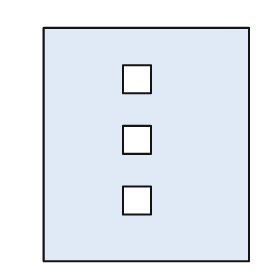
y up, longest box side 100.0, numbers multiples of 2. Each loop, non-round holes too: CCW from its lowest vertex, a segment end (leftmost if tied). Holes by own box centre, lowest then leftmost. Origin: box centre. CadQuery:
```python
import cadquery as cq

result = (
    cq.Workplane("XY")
    .moveTo(-44.0, -50.0)
    .lineTo(44.0, -50.0)
    .lineTo(44.0, 50.0)
    .lineTo(-44.0, 50.0)
    .close()
    .moveTo(-10.0, -30.0)
    .lineTo(2.0, -30.0)
    .lineTo(2.0, -18.0)
    .lineTo(-10.0, -18.0)
    .close()
    .moveTo(-10.0, -4.0)
    .lineTo(2.0, -4.0)
    .lineTo(2.0, 8.0)
    .lineTo(-10.0, 8.0)
    .close()
    .moveTo(-10.0, 22.0)
    .lineTo(2.0, 22.0)
    .lineTo(2.0, 34.0)
    .lineTo(-10.0, 34.0)
    .close()
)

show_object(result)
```